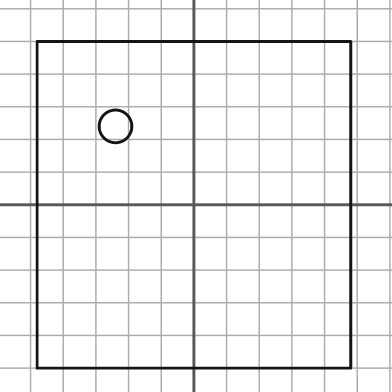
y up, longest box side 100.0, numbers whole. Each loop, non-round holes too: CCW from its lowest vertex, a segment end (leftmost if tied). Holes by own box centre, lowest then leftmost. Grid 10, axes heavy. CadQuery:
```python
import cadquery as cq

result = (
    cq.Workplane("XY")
    .moveTo(-48.0, -50.0)
    .lineTo(48.0, -50.0)
    .lineTo(48.0, 50.0)
    .lineTo(-48.0, 50.0)
    .close()
    .moveTo(-24.0, 24.0)
    .circle(5.0)
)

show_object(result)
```